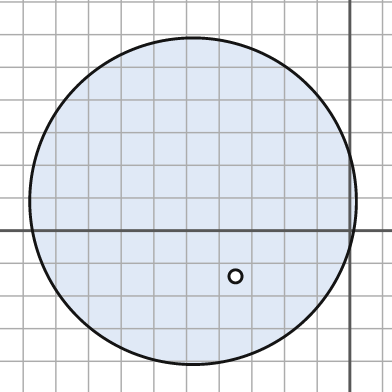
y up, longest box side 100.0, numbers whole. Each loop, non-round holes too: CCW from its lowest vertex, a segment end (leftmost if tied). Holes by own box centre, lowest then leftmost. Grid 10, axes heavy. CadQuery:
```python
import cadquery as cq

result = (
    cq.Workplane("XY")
    .moveTo(-48.0, 9.0)
    .circle(50.0)
    .moveTo(-35.0, -14.0)
    .circle(2.0)
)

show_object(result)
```